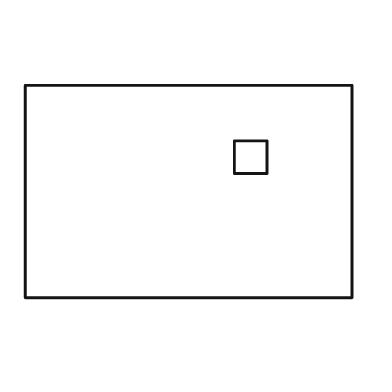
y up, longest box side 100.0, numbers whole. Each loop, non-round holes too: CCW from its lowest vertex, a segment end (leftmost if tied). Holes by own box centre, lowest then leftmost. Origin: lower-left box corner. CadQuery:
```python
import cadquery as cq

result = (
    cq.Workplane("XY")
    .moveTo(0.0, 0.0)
    .lineTo(100.0, 0.0)
    .lineTo(100.0, 65.0)
    .lineTo(0.0, 65.0)
    .close()
    .moveTo(64.0, 38.0)
    .lineTo(74.0, 38.0)
    .lineTo(74.0, 48.0)
    .lineTo(64.0, 48.0)
    .close()
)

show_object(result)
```